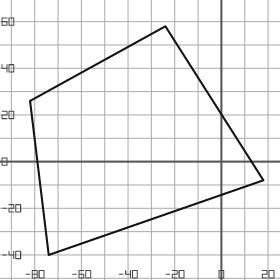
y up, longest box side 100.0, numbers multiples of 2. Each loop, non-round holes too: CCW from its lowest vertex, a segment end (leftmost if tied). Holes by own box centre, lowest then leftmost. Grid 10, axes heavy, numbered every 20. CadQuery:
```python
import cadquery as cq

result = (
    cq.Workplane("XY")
    .moveTo(-74.0, -40.0)
    .lineTo(18.0, -8.0)
    .lineTo(-24.0, 58.0)
    .lineTo(-82.0, 26.0)
    .close()
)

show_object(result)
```